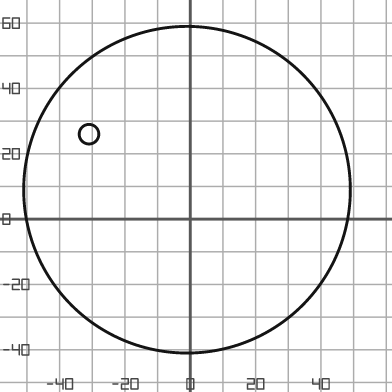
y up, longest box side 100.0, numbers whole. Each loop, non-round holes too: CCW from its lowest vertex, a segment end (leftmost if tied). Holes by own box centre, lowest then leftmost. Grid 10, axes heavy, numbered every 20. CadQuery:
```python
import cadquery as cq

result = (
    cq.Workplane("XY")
    .moveTo(-1.0, 9.0)
    .circle(50.0)
    .moveTo(-31.0, 26.0)
    .circle(3.0)
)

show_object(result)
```